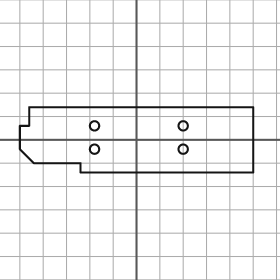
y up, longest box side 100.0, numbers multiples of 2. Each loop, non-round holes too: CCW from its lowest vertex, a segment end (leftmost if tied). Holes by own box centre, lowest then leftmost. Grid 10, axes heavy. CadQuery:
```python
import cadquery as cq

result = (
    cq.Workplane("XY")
    .moveTo(-24.0, -14.0)
    .lineTo(50.0, -14.0)
    .lineTo(50.0, 14.0)
    .lineTo(-46.0, 14.0)
    .lineTo(-46.0, 6.0)
    .lineTo(-50.0, 6.0)
    .lineTo(-50.0, -4.0)
    .lineTo(-44.0, -10.0)
    .lineTo(-24.0, -10.0)
    .close()
    .moveTo(-18.0, -4.0)
    .circle(2.0)
    .moveTo(20.0, -4.0)
    .circle(2.0)
    .moveTo(-18.0, 6.0)
    .circle(2.0)
    .moveTo(20.0, 6.0)
    .circle(2.0)
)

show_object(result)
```